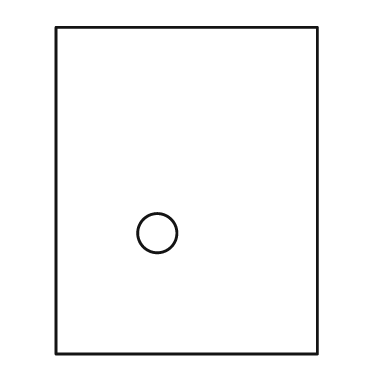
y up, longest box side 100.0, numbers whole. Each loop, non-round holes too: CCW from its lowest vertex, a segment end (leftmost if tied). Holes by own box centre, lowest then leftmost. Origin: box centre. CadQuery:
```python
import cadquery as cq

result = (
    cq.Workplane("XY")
    .moveTo(-40.0, -50.0)
    .lineTo(40.0, -50.0)
    .lineTo(40.0, 50.0)
    .lineTo(-40.0, 50.0)
    .close()
    .moveTo(-9.0, -13.0)
    .circle(6.0)
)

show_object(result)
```